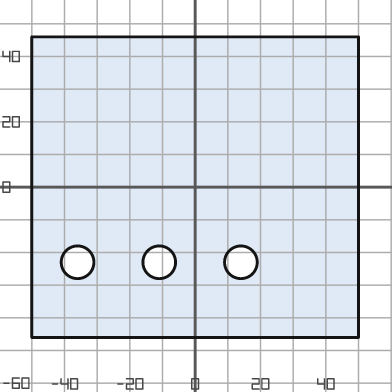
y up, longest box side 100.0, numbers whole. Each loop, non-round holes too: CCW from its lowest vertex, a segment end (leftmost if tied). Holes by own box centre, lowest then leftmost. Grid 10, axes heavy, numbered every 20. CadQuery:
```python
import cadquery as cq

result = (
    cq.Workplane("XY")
    .moveTo(-50.0, -46.0)
    .lineTo(50.0, -46.0)
    .lineTo(50.0, 46.0)
    .lineTo(-50.0, 46.0)
    .close()
    .moveTo(-36.0, -23.0)
    .circle(5.0)
    .moveTo(-11.0, -23.0)
    .circle(5.0)
    .moveTo(14.0, -23.0)
    .circle(5.0)
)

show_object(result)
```